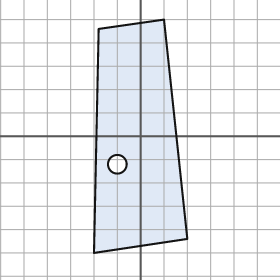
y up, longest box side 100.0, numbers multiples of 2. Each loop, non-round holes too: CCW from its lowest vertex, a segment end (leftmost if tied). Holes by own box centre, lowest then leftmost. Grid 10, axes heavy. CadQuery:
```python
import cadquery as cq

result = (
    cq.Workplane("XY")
    .moveTo(-20.0, -50.0)
    .lineTo(20.0, -44.0)
    .lineTo(10.0, 50.0)
    .lineTo(-18.0, 46.0)
    .close()
    .moveTo(-10.0, -12.0)
    .circle(4.0)
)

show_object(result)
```